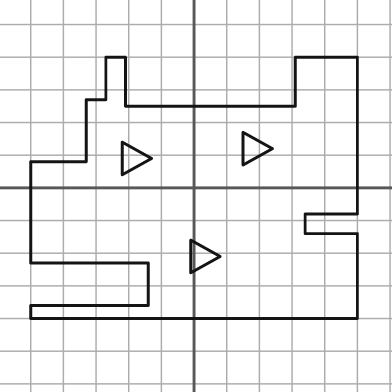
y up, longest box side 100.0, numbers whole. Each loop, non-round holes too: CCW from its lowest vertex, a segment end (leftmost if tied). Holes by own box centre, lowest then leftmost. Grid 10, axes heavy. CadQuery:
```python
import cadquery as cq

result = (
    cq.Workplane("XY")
    .moveTo(-50.0, -40.0)
    .lineTo(50.0, -40.0)
    .lineTo(50.0, -14.0)
    .lineTo(34.0, -14.0)
    .lineTo(34.0, -8.0)
    .lineTo(50.0, -8.0)
    .lineTo(50.0, 40.0)
    .lineTo(31.0, 40.0)
    .lineTo(31.0, 25.0)
    .lineTo(-21.0, 25.0)
    .lineTo(-21.0, 40.0)
    .lineTo(-27.0, 40.0)
    .lineTo(-27.0, 27.0)
    .lineTo(-33.0, 27.0)
    .lineTo(-33.0, 8.0)
    .lineTo(-50.0, 8.0)
    .lineTo(-50.0, -23.0)
    .lineTo(-14.0, -23.0)
    .lineTo(-14.0, -36.0)
    .lineTo(-50.0, -36.0)
    .close()
    .moveTo(-1.0, -26.0)
    .lineTo(8.0, -21.0)
    .lineTo(-1.0, -16.0)
    .close()
    .moveTo(-22.0, 4.0)
    .lineTo(-13.0, 9.0)
    .lineTo(-22.0, 14.0)
    .close()
    .moveTo(15.0, 7.0)
    .lineTo(24.0, 12.0)
    .lineTo(15.0, 17.0)
    .close()
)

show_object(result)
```